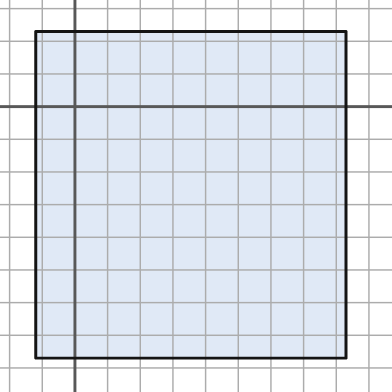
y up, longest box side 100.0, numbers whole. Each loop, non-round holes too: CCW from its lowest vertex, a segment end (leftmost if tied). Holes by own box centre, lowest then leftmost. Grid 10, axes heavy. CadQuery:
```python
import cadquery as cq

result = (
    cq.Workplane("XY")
    .moveTo(-12.0, -77.0)
    .lineTo(83.0, -77.0)
    .lineTo(83.0, 23.0)
    .lineTo(-12.0, 23.0)
    .close()
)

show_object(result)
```